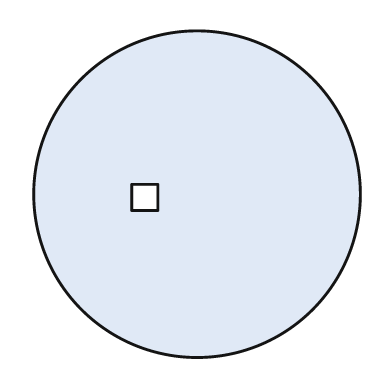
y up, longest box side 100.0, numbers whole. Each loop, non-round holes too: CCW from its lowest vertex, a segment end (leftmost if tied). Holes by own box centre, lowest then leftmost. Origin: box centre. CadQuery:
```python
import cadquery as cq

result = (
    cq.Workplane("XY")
    .moveTo(0.0, 0.0)
    .circle(50.0)
    .moveTo(-20.0, -5.0)
    .lineTo(-12.0, -5.0)
    .lineTo(-12.0, 3.0)
    .lineTo(-20.0, 3.0)
    .close()
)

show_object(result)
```